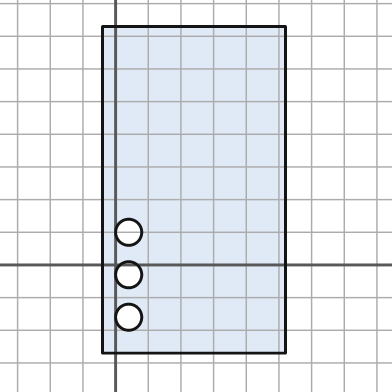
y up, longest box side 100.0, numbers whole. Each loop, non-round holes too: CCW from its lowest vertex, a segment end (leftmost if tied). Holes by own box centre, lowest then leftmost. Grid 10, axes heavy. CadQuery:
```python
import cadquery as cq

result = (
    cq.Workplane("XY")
    .moveTo(-4.0, -27.0)
    .lineTo(52.0, -27.0)
    .lineTo(52.0, 73.0)
    .lineTo(-4.0, 73.0)
    .close()
    .moveTo(4.0, -16.0)
    .circle(4.0)
    .moveTo(4.0, -3.0)
    .circle(4.0)
    .moveTo(4.0, 10.0)
    .circle(4.0)
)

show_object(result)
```